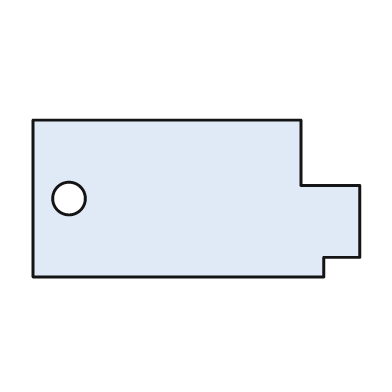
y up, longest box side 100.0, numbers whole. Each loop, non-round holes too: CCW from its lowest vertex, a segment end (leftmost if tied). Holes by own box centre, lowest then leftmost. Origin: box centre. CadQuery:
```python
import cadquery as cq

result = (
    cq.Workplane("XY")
    .moveTo(-50.0, -24.0)
    .lineTo(39.0, -24.0)
    .lineTo(39.0, -18.0)
    .lineTo(50.0, -18.0)
    .lineTo(50.0, 4.0)
    .lineTo(32.0, 4.0)
    .lineTo(32.0, 24.0)
    .lineTo(-50.0, 24.0)
    .close()
    .moveTo(-39.0, 0.0)
    .circle(5.0)
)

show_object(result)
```